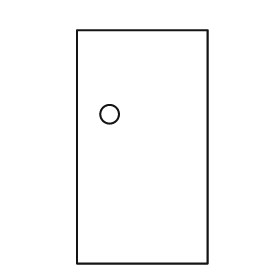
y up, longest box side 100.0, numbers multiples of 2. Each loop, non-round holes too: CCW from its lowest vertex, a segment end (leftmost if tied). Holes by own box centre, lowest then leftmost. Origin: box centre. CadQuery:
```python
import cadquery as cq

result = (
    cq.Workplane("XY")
    .moveTo(-28.0, -50.0)
    .lineTo(28.0, -50.0)
    .lineTo(28.0, 50.0)
    .lineTo(-28.0, 50.0)
    .close()
    .moveTo(-14.0, 14.0)
    .circle(4.0)
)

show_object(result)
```